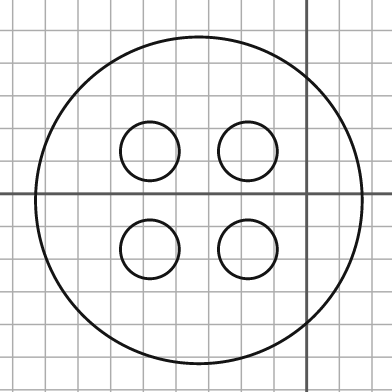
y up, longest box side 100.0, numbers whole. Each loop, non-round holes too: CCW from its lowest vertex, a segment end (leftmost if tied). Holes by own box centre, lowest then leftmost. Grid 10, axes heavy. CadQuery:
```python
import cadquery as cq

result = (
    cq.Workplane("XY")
    .moveTo(-33.0, -2.0)
    .circle(50.0)
    .moveTo(-48.0, -17.0)
    .circle(9.0)
    .moveTo(-18.0, -17.0)
    .circle(9.0)
    .moveTo(-48.0, 13.0)
    .circle(9.0)
    .moveTo(-18.0, 13.0)
    .circle(9.0)
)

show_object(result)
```